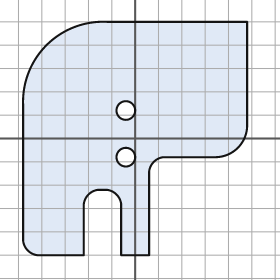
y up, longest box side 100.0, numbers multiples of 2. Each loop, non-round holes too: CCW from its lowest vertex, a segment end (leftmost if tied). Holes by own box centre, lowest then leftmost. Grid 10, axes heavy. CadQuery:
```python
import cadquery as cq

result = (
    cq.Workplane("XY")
    .moveTo(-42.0, -50.0)
    .lineTo(-22.0, -50.0)
    .lineTo(-22.0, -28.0)
    .threePointArc((-20.0, -24.0), (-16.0, -22.0))
    .lineTo(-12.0, -22.0)
    .threePointArc((-8.0, -24.0), (-6.0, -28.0))
    .lineTo(-6.0, -50.0)
    .lineTo(6.0, -50.0)
    .lineTo(6.0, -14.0)
    .threePointArc((8.0, -10.0), (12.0, -8.0))
    .lineTo(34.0, -8.0)
    .threePointArc((44.0, -4.0), (48.0, 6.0))
    .lineTo(48.0, 50.0)
    .lineTo(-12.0, 50.0)
    .threePointArc((-38.0, 40.0), (-48.0, 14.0))
    .lineTo(-48.0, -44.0)
    .threePointArc((-46.0, -48.0), (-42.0, -50.0))
    .close()
    .moveTo(-4.0, -8.0)
    .circle(4.0)
    .moveTo(-4.0, 12.0)
    .circle(4.0)
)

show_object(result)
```